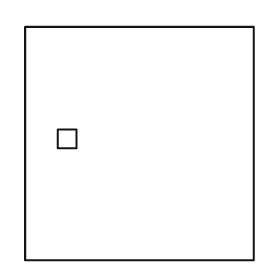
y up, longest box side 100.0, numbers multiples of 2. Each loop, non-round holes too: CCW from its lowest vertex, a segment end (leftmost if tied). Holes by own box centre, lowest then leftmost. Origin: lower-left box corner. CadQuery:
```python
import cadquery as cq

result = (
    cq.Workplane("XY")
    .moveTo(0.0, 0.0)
    .lineTo(98.0, 0.0)
    .lineTo(98.0, 100.0)
    .lineTo(0.0, 100.0)
    .close()
    .moveTo(14.0, 48.0)
    .lineTo(22.0, 48.0)
    .lineTo(22.0, 56.0)
    .lineTo(14.0, 56.0)
    .close()
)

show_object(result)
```